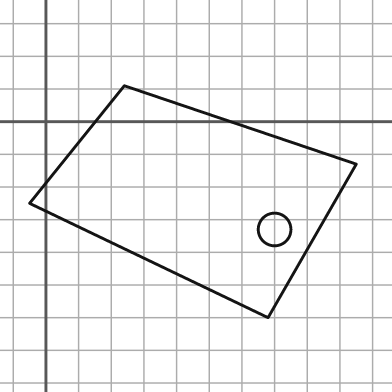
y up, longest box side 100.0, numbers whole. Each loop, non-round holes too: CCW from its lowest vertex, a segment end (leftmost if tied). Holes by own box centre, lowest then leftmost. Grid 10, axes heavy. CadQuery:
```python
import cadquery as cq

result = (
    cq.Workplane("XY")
    .moveTo(68.0, -60.0)
    .lineTo(95.0, -13.0)
    .lineTo(24.0, 11.0)
    .lineTo(-5.0, -25.0)
    .close()
    .moveTo(70.0, -33.0)
    .circle(5.0)
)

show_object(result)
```